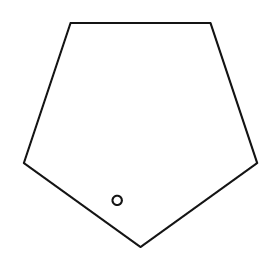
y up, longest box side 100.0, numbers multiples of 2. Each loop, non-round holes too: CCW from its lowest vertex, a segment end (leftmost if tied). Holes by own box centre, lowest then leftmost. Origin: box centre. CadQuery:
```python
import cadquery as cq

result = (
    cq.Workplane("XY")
    .moveTo(0.0, -48.0)
    .lineTo(50.0, -12.0)
    .lineTo(30.0, 48.0)
    .lineTo(-30.0, 48.0)
    .lineTo(-50.0, -12.0)
    .close()
    .moveTo(-10.0, -28.0)
    .circle(2.0)
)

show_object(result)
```